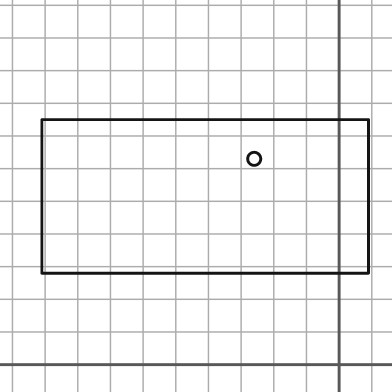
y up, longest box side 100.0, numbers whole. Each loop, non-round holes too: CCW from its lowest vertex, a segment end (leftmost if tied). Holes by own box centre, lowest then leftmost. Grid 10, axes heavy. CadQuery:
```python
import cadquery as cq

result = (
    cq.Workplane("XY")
    .moveTo(-91.0, 28.0)
    .lineTo(9.0, 28.0)
    .lineTo(9.0, 75.0)
    .lineTo(-91.0, 75.0)
    .close()
    .moveTo(-26.0, 63.0)
    .circle(2.0)
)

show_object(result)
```